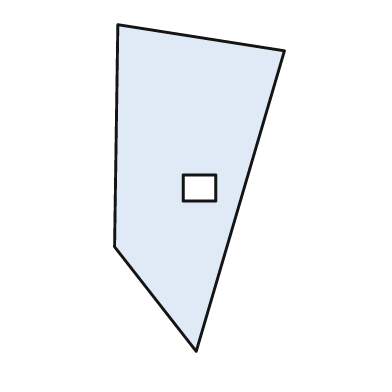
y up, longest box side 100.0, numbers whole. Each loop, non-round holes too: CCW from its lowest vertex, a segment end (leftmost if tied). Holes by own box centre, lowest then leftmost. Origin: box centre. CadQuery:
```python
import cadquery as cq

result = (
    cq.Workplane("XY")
    .moveTo(-1.0, -50.0)
    .lineTo(26.0, 42.0)
    .lineTo(-25.0, 50.0)
    .lineTo(-26.0, -18.0)
    .close()
    .moveTo(-5.0, -4.0)
    .lineTo(5.0, -4.0)
    .lineTo(5.0, 4.0)
    .lineTo(-5.0, 4.0)
    .close()
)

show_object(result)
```